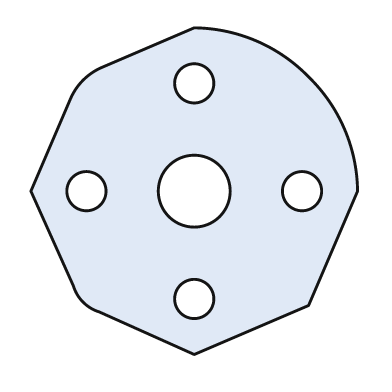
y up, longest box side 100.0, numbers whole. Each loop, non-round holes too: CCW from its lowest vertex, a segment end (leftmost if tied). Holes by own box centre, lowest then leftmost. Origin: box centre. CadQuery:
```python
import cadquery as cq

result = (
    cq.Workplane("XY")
    .moveTo(0.0, -50.0)
    .lineTo(35.0, -35.0)
    .lineTo(50.0, 0.0)
    .threePointArc((46.0, 19.0), (35.0, 35.0))
    .threePointArc((19.0, 46.0), (0.0, 50.0))
    .lineTo(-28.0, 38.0)
    .threePointArc((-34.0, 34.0), (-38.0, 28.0))
    .lineTo(-50.0, 0.0)
    .lineTo(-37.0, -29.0)
    .threePointArc((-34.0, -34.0), (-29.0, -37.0))
    .close()
    .moveTo(0.0, -33.0)
    .circle(6.0)
    .moveTo(-33.0, 0.0)
    .circle(6.0)
    .moveTo(0.0, 0.0)
    .circle(11.0)
    .moveTo(33.0, 0.0)
    .circle(6.0)
    .moveTo(0.0, 33.0)
    .circle(6.0)
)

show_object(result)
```